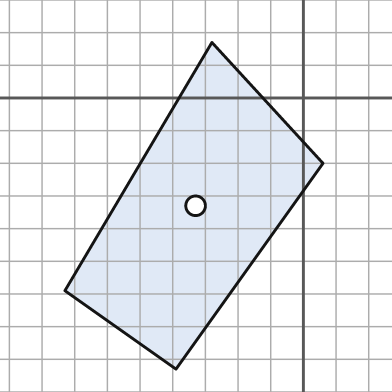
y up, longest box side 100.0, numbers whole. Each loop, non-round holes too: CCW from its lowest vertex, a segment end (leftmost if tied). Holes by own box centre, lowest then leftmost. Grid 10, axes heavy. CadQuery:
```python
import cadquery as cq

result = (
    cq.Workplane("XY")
    .moveTo(-39.0, -83.0)
    .lineTo(6.0, -20.0)
    .lineTo(-28.0, 17.0)
    .lineTo(-73.0, -59.0)
    .close()
    .moveTo(-33.0, -33.0)
    .circle(3.0)
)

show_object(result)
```